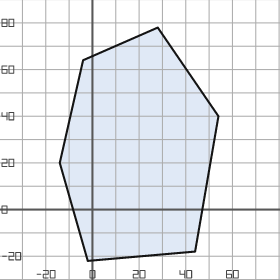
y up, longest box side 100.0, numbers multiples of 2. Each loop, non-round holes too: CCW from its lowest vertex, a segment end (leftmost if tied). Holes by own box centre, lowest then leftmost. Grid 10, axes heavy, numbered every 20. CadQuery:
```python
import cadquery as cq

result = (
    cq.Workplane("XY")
    .moveTo(-2.0, -22.0)
    .lineTo(44.0, -18.0)
    .lineTo(54.0, 40.0)
    .lineTo(28.0, 78.0)
    .lineTo(-4.0, 64.0)
    .lineTo(-14.0, 20.0)
    .close()
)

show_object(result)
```